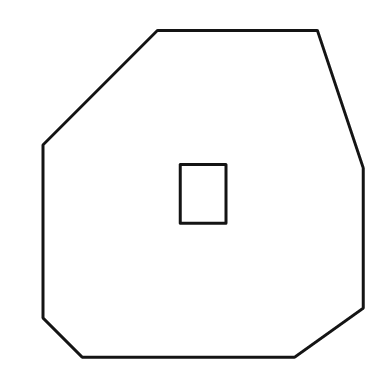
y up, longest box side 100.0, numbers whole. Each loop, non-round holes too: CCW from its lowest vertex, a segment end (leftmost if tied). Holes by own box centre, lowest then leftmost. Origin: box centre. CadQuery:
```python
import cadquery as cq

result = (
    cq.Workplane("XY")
    .moveTo(-37.0, -50.0)
    .lineTo(28.0, -50.0)
    .lineTo(49.0, -35.0)
    .lineTo(49.0, 8.0)
    .lineTo(35.0, 50.0)
    .lineTo(-14.0, 50.0)
    .lineTo(-49.0, 15.0)
    .lineTo(-49.0, -38.0)
    .close()
    .moveTo(-7.0, -9.0)
    .lineTo(7.0, -9.0)
    .lineTo(7.0, 9.0)
    .lineTo(-7.0, 9.0)
    .close()
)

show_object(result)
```